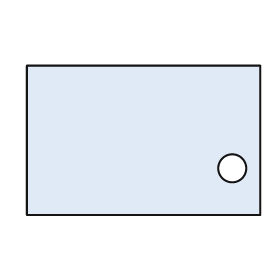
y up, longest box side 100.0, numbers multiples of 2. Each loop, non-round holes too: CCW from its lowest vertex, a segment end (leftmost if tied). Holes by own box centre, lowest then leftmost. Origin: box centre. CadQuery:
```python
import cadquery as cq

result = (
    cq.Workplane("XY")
    .moveTo(-50.0, -32.0)
    .lineTo(50.0, -32.0)
    .lineTo(50.0, 32.0)
    .lineTo(-50.0, 32.0)
    .close()
    .moveTo(38.0, -12.0)
    .circle(6.0)
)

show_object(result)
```